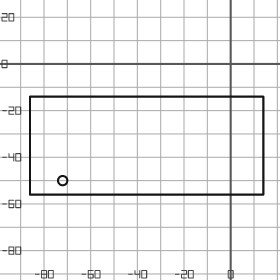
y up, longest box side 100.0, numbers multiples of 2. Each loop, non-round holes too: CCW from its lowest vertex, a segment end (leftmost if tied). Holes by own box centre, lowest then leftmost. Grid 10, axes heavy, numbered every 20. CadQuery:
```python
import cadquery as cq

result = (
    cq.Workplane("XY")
    .moveTo(-86.0, -56.0)
    .lineTo(14.0, -56.0)
    .lineTo(14.0, -14.0)
    .lineTo(-86.0, -14.0)
    .close()
    .moveTo(-72.0, -50.0)
    .circle(2.0)
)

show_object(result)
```